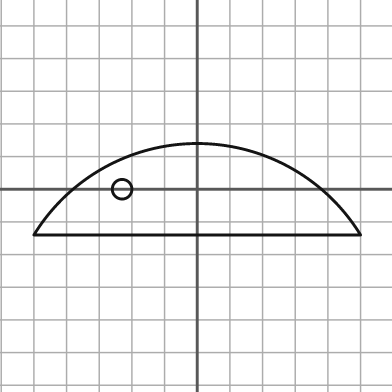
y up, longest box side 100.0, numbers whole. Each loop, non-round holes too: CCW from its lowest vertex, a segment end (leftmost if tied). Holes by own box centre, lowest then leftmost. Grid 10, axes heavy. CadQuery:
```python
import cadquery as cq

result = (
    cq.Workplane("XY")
    .moveTo(-50.0, -14.0)
    .lineTo(50.0, -14.0)
    .threePointArc((0.0, 14.0), (-50.0, -14.0))
    .close()
    .moveTo(-23.0, 0.0)
    .circle(3.0)
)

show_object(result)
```